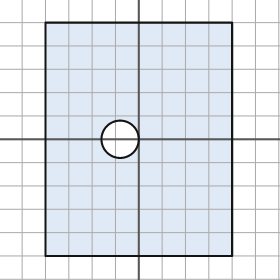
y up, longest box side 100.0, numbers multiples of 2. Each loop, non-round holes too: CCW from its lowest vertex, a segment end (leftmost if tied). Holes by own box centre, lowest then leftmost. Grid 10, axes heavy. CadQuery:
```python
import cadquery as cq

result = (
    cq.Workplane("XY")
    .moveTo(-40.0, -50.0)
    .lineTo(40.0, -50.0)
    .lineTo(40.0, 50.0)
    .lineTo(-40.0, 50.0)
    .close()
    .moveTo(-8.0, 0.0)
    .circle(8.0)
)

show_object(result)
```